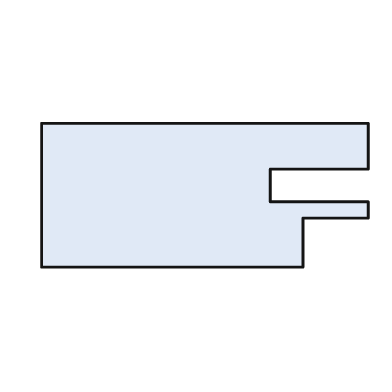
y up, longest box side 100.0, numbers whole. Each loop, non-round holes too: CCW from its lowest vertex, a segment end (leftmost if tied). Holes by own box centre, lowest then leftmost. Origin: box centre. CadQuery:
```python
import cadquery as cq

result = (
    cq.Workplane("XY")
    .moveTo(-50.0, -22.0)
    .lineTo(30.0, -22.0)
    .lineTo(30.0, -7.0)
    .lineTo(50.0, -7.0)
    .lineTo(50.0, -2.0)
    .lineTo(20.0, -2.0)
    .lineTo(20.0, 8.0)
    .lineTo(50.0, 8.0)
    .lineTo(50.0, 22.0)
    .lineTo(-50.0, 22.0)
    .close()
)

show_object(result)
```